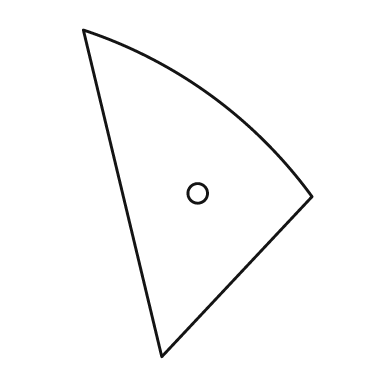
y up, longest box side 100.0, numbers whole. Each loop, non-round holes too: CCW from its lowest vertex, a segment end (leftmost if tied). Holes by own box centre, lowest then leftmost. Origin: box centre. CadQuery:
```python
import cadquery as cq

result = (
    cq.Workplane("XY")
    .moveTo(-11.0, -50.0)
    .lineTo(35.0, -1.0)
    .threePointArc((4.0, 30.0), (-35.0, 50.0))
    .close()
    .moveTo(0.0, 0.0)
    .circle(3.0)
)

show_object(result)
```